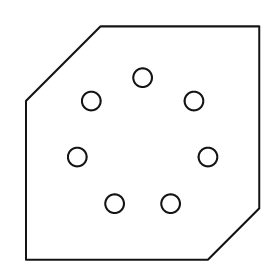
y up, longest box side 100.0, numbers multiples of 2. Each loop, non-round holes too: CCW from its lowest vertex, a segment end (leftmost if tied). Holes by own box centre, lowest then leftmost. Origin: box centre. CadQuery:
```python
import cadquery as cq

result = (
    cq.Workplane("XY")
    .moveTo(-50.0, -50.0)
    .lineTo(28.0, -50.0)
    .lineTo(50.0, -28.0)
    .lineTo(50.0, 50.0)
    .lineTo(-18.0, 50.0)
    .lineTo(-50.0, 18.0)
    .close()
    .moveTo(-12.0, -26.0)
    .circle(4.0)
    .moveTo(12.0, -26.0)
    .circle(4.0)
    .moveTo(-28.0, -6.0)
    .circle(4.0)
    .moveTo(28.0, -6.0)
    .circle(4.0)
    .moveTo(-22.0, 18.0)
    .circle(4.0)
    .moveTo(22.0, 18.0)
    .circle(4.0)
    .moveTo(0.0, 28.0)
    .circle(4.0)
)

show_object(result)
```